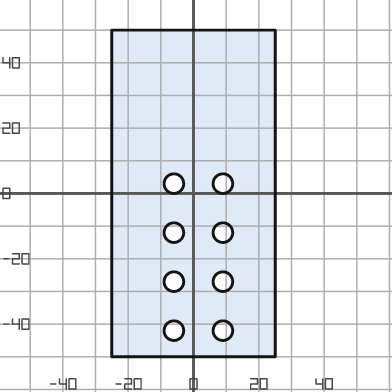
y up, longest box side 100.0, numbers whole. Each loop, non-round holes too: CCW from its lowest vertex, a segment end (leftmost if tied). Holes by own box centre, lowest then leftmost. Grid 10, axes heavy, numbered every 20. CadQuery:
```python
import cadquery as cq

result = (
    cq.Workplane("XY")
    .moveTo(-25.0, -50.0)
    .lineTo(25.0, -50.0)
    .lineTo(25.0, 50.0)
    .lineTo(-25.0, 50.0)
    .close()
    .moveTo(-6.0, -42.0)
    .circle(3.0)
    .moveTo(9.0, -42.0)
    .circle(3.0)
    .moveTo(-6.0, -27.0)
    .circle(3.0)
    .moveTo(9.0, -27.0)
    .circle(3.0)
    .moveTo(-6.0, -12.0)
    .circle(3.0)
    .moveTo(9.0, -12.0)
    .circle(3.0)
    .moveTo(-6.0, 3.0)
    .circle(3.0)
    .moveTo(9.0, 3.0)
    .circle(3.0)
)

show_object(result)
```